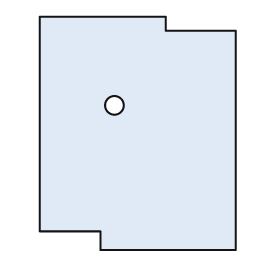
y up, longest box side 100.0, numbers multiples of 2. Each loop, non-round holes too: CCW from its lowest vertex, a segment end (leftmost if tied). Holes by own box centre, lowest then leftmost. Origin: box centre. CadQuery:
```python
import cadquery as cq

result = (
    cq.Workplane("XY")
    .moveTo(-16.0, -50.0)
    .lineTo(42.0, -50.0)
    .lineTo(42.0, 44.0)
    .lineTo(12.0, 44.0)
    .lineTo(12.0, 50.0)
    .lineTo(-42.0, 50.0)
    .lineTo(-42.0, -42.0)
    .lineTo(-16.0, -42.0)
    .close()
    .moveTo(-10.0, 12.0)
    .circle(4.0)
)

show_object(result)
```